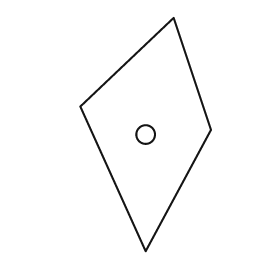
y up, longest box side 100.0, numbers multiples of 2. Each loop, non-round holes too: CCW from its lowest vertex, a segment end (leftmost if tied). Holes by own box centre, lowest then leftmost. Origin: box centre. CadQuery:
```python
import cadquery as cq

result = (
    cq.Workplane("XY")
    .moveTo(0.0, -50.0)
    .lineTo(28.0, 2.0)
    .lineTo(12.0, 50.0)
    .lineTo(-28.0, 12.0)
    .close()
    .moveTo(0.0, 0.0)
    .circle(4.0)
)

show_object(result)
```